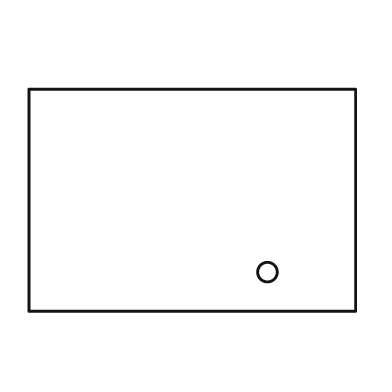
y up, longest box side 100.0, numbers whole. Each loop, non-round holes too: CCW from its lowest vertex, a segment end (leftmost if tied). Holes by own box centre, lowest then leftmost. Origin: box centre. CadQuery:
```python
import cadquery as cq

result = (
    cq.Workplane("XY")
    .moveTo(-50.0, -34.0)
    .lineTo(50.0, -34.0)
    .lineTo(50.0, 34.0)
    .lineTo(-50.0, 34.0)
    .close()
    .moveTo(23.0, -22.0)
    .circle(3.0)
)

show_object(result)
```